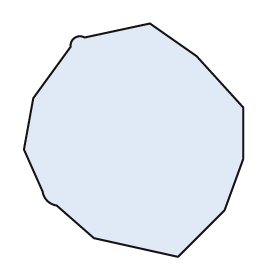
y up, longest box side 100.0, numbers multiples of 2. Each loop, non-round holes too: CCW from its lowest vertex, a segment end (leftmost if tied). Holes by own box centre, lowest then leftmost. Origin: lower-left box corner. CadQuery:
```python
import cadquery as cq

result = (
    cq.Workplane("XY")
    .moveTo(66.0, 0.0)
    .lineTo(86.0, 20.0)
    .lineTo(94.0, 42.0)
    .lineTo(94.0, 64.0)
    .lineTo(74.0, 86.0)
    .lineTo(54.0, 100.0)
    .lineTo(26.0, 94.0)
    .threePointArc((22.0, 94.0), (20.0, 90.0))
    .lineTo(4.0, 68.0)
    .lineTo(0.0, 46.0)
    .lineTo(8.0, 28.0)
    .threePointArc((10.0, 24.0), (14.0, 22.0))
    .lineTo(30.0, 8.0)
    .close()
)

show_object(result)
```